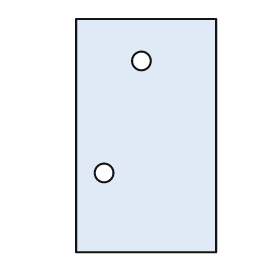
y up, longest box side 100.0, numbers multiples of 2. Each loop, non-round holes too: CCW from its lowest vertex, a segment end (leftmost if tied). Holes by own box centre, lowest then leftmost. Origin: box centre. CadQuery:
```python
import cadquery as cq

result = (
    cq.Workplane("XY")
    .moveTo(-30.0, -50.0)
    .lineTo(30.0, -50.0)
    .lineTo(30.0, 50.0)
    .lineTo(-30.0, 50.0)
    .close()
    .moveTo(-18.0, -16.0)
    .circle(4.0)
    .moveTo(-2.0, 32.0)
    .circle(4.0)
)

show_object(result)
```